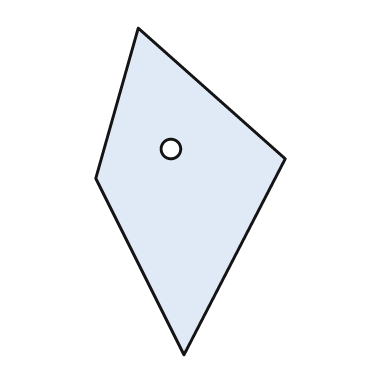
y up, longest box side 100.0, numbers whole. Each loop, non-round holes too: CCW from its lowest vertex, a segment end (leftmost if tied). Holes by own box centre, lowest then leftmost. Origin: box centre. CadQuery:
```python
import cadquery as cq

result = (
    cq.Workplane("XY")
    .moveTo(-2.0, -50.0)
    .lineTo(29.0, 10.0)
    .lineTo(-16.0, 50.0)
    .lineTo(-29.0, 4.0)
    .close()
    .moveTo(-6.0, 13.0)
    .circle(3.0)
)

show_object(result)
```